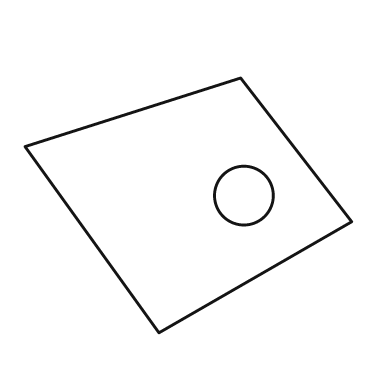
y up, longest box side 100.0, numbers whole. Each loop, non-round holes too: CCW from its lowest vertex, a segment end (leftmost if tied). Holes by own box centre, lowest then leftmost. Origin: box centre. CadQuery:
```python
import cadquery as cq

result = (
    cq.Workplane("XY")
    .moveTo(-9.0, -39.0)
    .lineTo(50.0, -5.0)
    .lineTo(16.0, 39.0)
    .lineTo(-50.0, 18.0)
    .close()
    .moveTo(17.0, 3.0)
    .circle(9.0)
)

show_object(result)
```